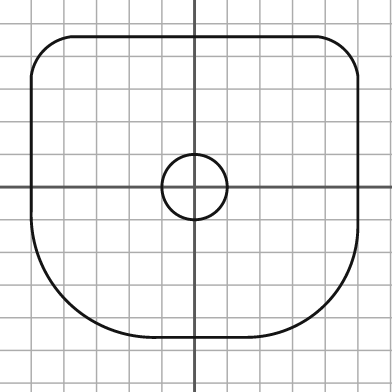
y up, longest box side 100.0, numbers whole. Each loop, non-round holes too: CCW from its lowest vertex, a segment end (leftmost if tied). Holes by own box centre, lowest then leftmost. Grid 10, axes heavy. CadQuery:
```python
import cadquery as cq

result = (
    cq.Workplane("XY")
    .moveTo(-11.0, -46.0)
    .lineTo(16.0, -46.0)
    .threePointArc((40.0, -36.0), (50.0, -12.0))
    .lineTo(50.0, 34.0)
    .threePointArc((46.0, 42.0), (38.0, 46.0))
    .lineTo(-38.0, 46.0)
    .threePointArc((-46.0, 42.0), (-50.0, 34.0))
    .lineTo(-50.0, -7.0)
    .threePointArc((-39.0, -35.0), (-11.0, -46.0))
    .close()
    .moveTo(0.0, 0.0)
    .circle(10.0)
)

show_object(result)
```